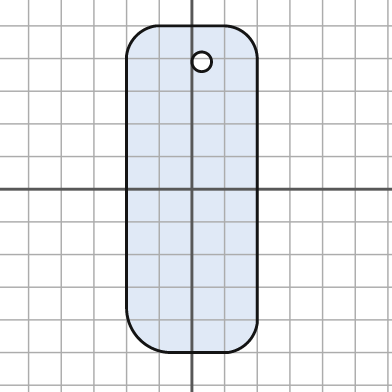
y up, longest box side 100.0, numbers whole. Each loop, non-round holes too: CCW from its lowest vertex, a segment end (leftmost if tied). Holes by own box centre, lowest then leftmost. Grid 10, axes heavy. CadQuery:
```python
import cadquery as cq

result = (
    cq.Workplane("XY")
    .moveTo(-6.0, -50.0)
    .lineTo(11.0, -50.0)
    .threePointArc((17.0, -47.0), (20.0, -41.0))
    .lineTo(20.0, 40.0)
    .threePointArc((17.0, 47.0), (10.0, 50.0))
    .lineTo(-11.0, 50.0)
    .threePointArc((-17.0, 47.0), (-20.0, 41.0))
    .lineTo(-20.0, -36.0)
    .threePointArc((-16.0, -46.0), (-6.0, -50.0))
    .close()
    .moveTo(3.0, 39.0)
    .circle(3.0)
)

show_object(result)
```